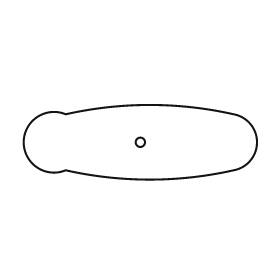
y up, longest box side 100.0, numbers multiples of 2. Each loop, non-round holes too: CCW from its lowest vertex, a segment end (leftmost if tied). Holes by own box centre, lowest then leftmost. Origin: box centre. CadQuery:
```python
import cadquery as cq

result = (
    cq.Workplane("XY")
    .moveTo(-32.0, -12.0)
    .threePointArc((4.0, -16.0), (40.0, -12.0))
    .threePointArc((50.0, 0.0), (40.0, 12.0))
    .threePointArc((4.0, 16.0), (-32.0, 12.0))
    .threePointArc((-50.0, 0.0), (-32.0, -12.0))
    .close()
    .moveTo(0.0, 0.0)
    .circle(2.0)
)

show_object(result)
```